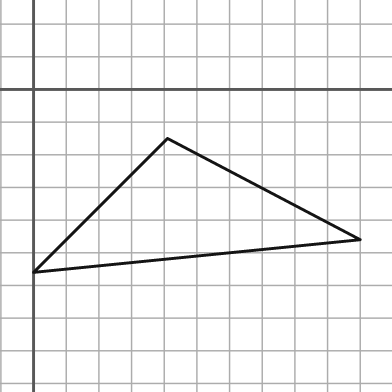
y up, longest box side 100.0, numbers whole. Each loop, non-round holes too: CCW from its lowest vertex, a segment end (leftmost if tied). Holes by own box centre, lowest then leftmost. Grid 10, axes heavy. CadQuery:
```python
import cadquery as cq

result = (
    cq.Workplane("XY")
    .moveTo(0.0, -56.0)
    .lineTo(100.0, -46.0)
    .lineTo(41.0, -15.0)
    .close()
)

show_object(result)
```